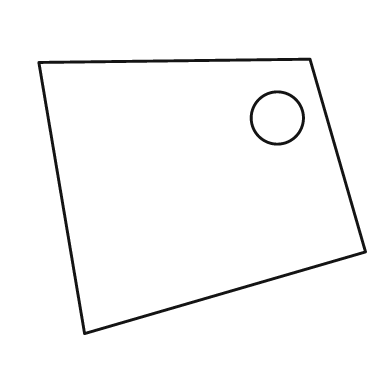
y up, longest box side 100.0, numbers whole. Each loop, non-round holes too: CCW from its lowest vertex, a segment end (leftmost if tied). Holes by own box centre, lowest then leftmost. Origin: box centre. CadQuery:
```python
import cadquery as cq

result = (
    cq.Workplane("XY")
    .moveTo(-36.0, -42.0)
    .lineTo(50.0, -17.0)
    .lineTo(33.0, 42.0)
    .lineTo(-50.0, 41.0)
    .close()
    .moveTo(23.0, 24.0)
    .circle(8.0)
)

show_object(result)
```